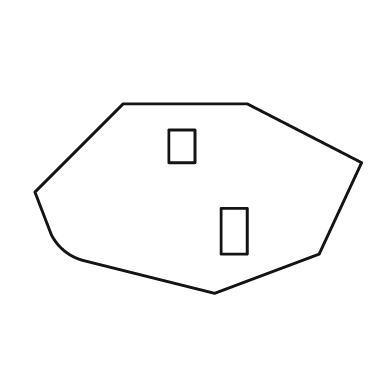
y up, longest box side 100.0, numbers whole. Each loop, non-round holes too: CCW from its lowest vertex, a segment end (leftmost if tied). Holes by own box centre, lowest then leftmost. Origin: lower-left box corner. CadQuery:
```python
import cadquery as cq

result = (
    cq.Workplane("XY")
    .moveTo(55.0, 0.0)
    .lineTo(87.0, 12.0)
    .lineTo(100.0, 40.0)
    .lineTo(65.0, 58.0)
    .lineTo(27.0, 58.0)
    .lineTo(0.0, 31.0)
    .lineTo(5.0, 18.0)
    .threePointArc((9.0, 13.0), (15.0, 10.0))
    .close()
    .moveTo(57.0, 12.0)
    .lineTo(65.0, 12.0)
    .lineTo(65.0, 26.0)
    .lineTo(57.0, 26.0)
    .close()
    .moveTo(41.0, 40.0)
    .lineTo(49.0, 40.0)
    .lineTo(49.0, 50.0)
    .lineTo(41.0, 50.0)
    .close()
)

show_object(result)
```